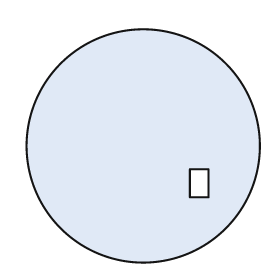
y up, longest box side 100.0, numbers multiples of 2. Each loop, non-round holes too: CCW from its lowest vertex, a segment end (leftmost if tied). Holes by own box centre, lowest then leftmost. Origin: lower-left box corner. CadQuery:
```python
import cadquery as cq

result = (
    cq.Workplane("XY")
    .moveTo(50.0, 50.0)
    .circle(50.0)
    .moveTo(70.0, 28.0)
    .lineTo(78.0, 28.0)
    .lineTo(78.0, 40.0)
    .lineTo(70.0, 40.0)
    .close()
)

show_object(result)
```